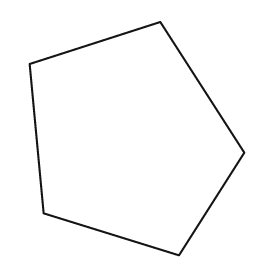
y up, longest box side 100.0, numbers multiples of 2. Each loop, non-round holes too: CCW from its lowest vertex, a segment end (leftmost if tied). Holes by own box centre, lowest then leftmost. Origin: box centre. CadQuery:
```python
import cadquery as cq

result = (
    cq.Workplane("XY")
    .moveTo(18.0, -50.0)
    .lineTo(46.0, -6.0)
    .lineTo(10.0, 50.0)
    .lineTo(-46.0, 32.0)
    .lineTo(-40.0, -32.0)
    .close()
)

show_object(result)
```